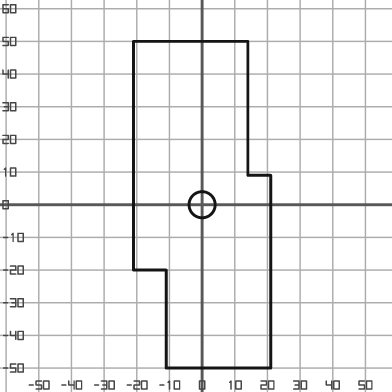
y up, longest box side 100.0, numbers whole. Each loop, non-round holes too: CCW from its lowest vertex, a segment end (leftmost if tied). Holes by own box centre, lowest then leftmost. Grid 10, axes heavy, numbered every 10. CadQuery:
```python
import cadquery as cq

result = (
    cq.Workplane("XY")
    .moveTo(-11.0, -50.0)
    .lineTo(21.0, -50.0)
    .lineTo(21.0, 9.0)
    .lineTo(14.0, 9.0)
    .lineTo(14.0, 50.0)
    .lineTo(-21.0, 50.0)
    .lineTo(-21.0, -20.0)
    .lineTo(-11.0, -20.0)
    .close()
    .moveTo(0.0, 0.0)
    .circle(4.0)
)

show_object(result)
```